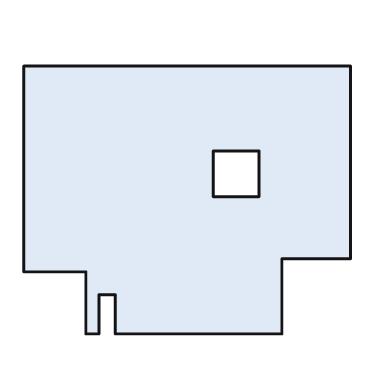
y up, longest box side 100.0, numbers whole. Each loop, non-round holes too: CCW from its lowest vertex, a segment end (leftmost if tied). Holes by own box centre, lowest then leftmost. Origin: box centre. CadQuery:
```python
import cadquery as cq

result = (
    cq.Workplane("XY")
    .moveTo(-31.0, -41.0)
    .lineTo(-27.0, -41.0)
    .lineTo(-27.0, -29.0)
    .lineTo(-22.0, -29.0)
    .lineTo(-22.0, -41.0)
    .lineTo(29.0, -41.0)
    .lineTo(29.0, -18.0)
    .lineTo(50.0, -18.0)
    .lineTo(50.0, 41.0)
    .lineTo(-50.0, 41.0)
    .lineTo(-50.0, -22.0)
    .lineTo(-31.0, -22.0)
    .close()
    .moveTo(8.0, 1.0)
    .lineTo(22.0, 1.0)
    .lineTo(22.0, 15.0)
    .lineTo(8.0, 15.0)
    .close()
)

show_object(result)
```